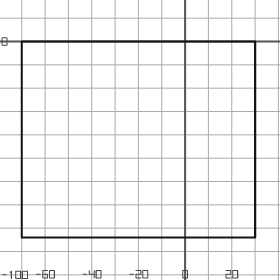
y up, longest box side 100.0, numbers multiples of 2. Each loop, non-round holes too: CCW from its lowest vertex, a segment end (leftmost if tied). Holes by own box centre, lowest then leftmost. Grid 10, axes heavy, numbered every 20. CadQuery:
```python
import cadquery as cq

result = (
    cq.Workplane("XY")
    .moveTo(-70.0, -84.0)
    .lineTo(30.0, -84.0)
    .lineTo(30.0, 0.0)
    .lineTo(-70.0, 0.0)
    .close()
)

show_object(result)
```